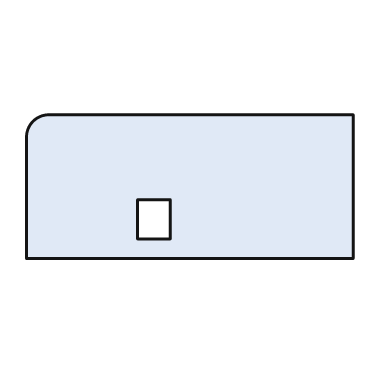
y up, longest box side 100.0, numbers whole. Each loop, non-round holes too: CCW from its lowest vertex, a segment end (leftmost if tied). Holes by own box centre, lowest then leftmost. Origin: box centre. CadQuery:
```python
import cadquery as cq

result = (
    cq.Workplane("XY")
    .moveTo(-50.0, -22.0)
    .lineTo(50.0, -22.0)
    .lineTo(50.0, 22.0)
    .lineTo(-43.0, 22.0)
    .threePointArc((-48.0, 20.0), (-50.0, 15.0))
    .close()
    .moveTo(-16.0, -16.0)
    .lineTo(-6.0, -16.0)
    .lineTo(-6.0, -4.0)
    .lineTo(-16.0, -4.0)
    .close()
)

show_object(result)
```